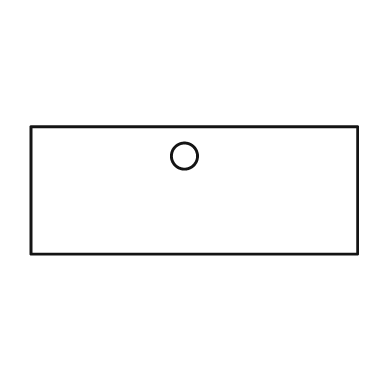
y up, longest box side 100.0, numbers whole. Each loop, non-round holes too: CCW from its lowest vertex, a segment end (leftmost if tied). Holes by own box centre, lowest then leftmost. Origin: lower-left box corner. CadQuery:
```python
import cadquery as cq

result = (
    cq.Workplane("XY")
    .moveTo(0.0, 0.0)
    .lineTo(100.0, 0.0)
    .lineTo(100.0, 39.0)
    .lineTo(0.0, 39.0)
    .close()
    .moveTo(47.0, 30.0)
    .circle(4.0)
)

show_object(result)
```